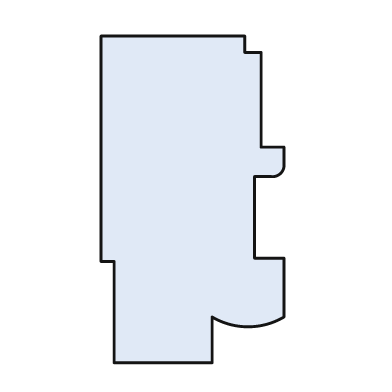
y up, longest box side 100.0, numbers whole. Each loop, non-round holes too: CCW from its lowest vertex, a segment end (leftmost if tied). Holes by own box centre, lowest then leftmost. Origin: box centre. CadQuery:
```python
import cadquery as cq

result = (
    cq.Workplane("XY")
    .moveTo(-24.0, -50.0)
    .lineTo(6.0, -50.0)
    .lineTo(6.0, -36.0)
    .threePointArc((17.0, -39.0), (28.0, -36.0))
    .lineTo(28.0, -18.0)
    .lineTo(19.0, -18.0)
    .lineTo(19.0, 7.0)
    .lineTo(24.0, 7.0)
    .threePointArc((27.0, 8.0), (28.0, 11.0))
    .lineTo(28.0, 16.0)
    .lineTo(21.0, 16.0)
    .lineTo(21.0, 45.0)
    .lineTo(16.0, 45.0)
    .lineTo(16.0, 50.0)
    .lineTo(-28.0, 50.0)
    .lineTo(-28.0, -19.0)
    .lineTo(-24.0, -19.0)
    .close()
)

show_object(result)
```